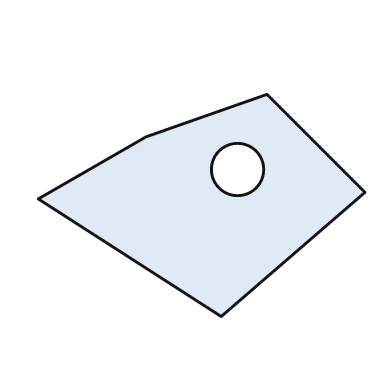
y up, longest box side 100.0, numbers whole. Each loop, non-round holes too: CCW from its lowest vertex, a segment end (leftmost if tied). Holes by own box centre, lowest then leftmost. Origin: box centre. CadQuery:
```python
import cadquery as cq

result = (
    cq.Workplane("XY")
    .moveTo(6.0, -34.0)
    .lineTo(50.0, 4.0)
    .lineTo(20.0, 34.0)
    .lineTo(-17.0, 21.0)
    .lineTo(-50.0, 2.0)
    .close()
    .moveTo(11.0, 11.0)
    .circle(8.0)
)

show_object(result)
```